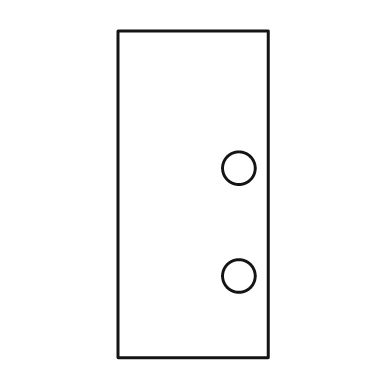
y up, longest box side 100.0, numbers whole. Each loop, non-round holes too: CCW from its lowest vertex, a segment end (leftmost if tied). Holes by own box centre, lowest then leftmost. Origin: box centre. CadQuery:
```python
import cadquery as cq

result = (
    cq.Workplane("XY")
    .moveTo(-23.0, -50.0)
    .lineTo(23.0, -50.0)
    .lineTo(23.0, 50.0)
    .lineTo(-23.0, 50.0)
    .close()
    .moveTo(14.0, -25.0)
    .circle(5.0)
    .moveTo(14.0, 8.0)
    .circle(5.0)
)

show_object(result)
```